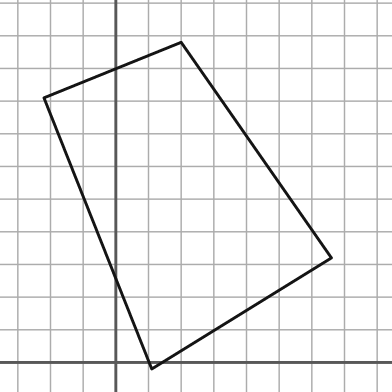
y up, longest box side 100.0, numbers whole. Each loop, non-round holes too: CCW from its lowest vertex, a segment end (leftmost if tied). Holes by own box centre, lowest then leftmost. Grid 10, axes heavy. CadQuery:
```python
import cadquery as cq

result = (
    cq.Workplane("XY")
    .moveTo(11.0, -2.0)
    .lineTo(66.0, 32.0)
    .lineTo(20.0, 98.0)
    .lineTo(-22.0, 81.0)
    .close()
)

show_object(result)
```